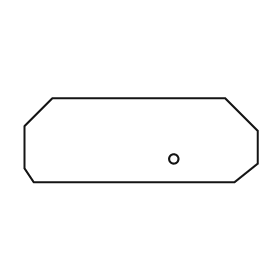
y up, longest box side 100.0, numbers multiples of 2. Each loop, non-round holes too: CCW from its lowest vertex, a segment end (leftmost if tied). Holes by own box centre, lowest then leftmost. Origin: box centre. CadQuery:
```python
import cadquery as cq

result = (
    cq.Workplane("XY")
    .moveTo(-46.0, -18.0)
    .lineTo(40.0, -18.0)
    .lineTo(50.0, -10.0)
    .lineTo(50.0, 4.0)
    .lineTo(36.0, 18.0)
    .lineTo(-38.0, 18.0)
    .lineTo(-50.0, 6.0)
    .lineTo(-50.0, -12.0)
    .close()
    .moveTo(14.0, -8.0)
    .circle(2.0)
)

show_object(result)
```